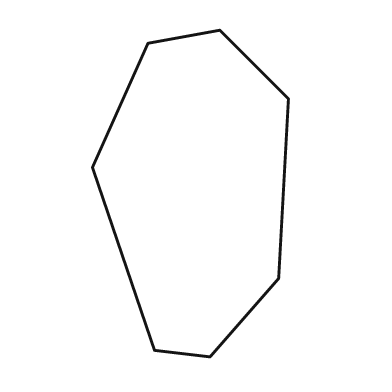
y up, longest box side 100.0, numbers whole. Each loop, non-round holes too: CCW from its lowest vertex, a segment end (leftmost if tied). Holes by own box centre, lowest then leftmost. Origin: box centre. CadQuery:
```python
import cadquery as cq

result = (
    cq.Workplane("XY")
    .moveTo(6.0, -50.0)
    .lineTo(27.0, -26.0)
    .lineTo(30.0, 29.0)
    .lineTo(9.0, 50.0)
    .lineTo(-13.0, 46.0)
    .lineTo(-30.0, 8.0)
    .lineTo(-11.0, -48.0)
    .close()
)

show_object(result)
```